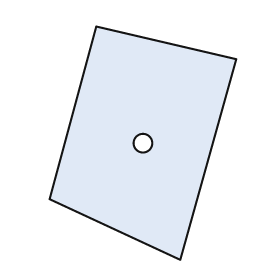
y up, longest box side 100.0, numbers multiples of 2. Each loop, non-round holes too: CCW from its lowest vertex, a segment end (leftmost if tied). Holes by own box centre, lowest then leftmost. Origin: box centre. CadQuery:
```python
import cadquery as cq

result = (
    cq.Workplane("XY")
    .moveTo(16.0, -50.0)
    .lineTo(40.0, 36.0)
    .lineTo(-20.0, 50.0)
    .lineTo(-40.0, -24.0)
    .close()
    .moveTo(0.0, 0.0)
    .circle(4.0)
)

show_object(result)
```